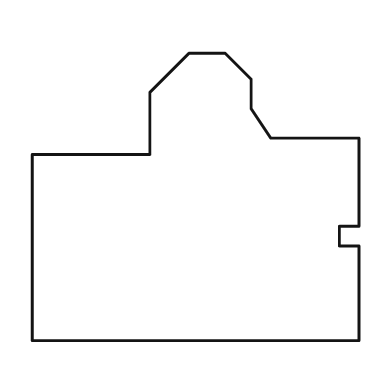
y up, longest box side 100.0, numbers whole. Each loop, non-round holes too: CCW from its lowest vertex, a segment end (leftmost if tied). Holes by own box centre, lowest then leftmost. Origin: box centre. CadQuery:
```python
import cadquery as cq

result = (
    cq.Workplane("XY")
    .moveTo(-50.0, -44.0)
    .lineTo(50.0, -44.0)
    .lineTo(50.0, -15.0)
    .lineTo(44.0, -15.0)
    .lineTo(44.0, -9.0)
    .lineTo(50.0, -9.0)
    .lineTo(50.0, 18.0)
    .lineTo(23.0, 18.0)
    .lineTo(17.0, 27.0)
    .lineTo(17.0, 36.0)
    .lineTo(9.0, 44.0)
    .lineTo(-2.0, 44.0)
    .lineTo(-14.0, 32.0)
    .lineTo(-14.0, 13.0)
    .lineTo(-50.0, 13.0)
    .close()
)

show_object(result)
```